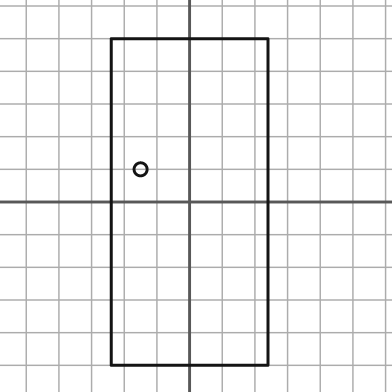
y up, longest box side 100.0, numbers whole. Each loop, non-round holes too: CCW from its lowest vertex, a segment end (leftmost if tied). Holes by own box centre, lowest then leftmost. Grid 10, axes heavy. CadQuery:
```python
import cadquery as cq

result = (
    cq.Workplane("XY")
    .moveTo(-24.0, -50.0)
    .lineTo(24.0, -50.0)
    .lineTo(24.0, 50.0)
    .lineTo(-24.0, 50.0)
    .close()
    .moveTo(-15.0, 10.0)
    .circle(2.0)
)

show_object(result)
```